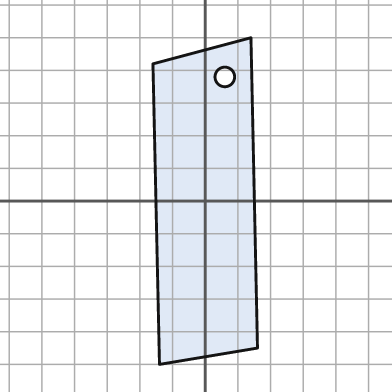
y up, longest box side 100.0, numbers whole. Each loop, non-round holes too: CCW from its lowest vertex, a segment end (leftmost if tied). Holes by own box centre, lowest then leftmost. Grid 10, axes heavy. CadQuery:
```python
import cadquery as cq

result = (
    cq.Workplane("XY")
    .moveTo(-14.0, -50.0)
    .lineTo(16.0, -45.0)
    .lineTo(14.0, 50.0)
    .lineTo(-16.0, 42.0)
    .close()
    .moveTo(6.0, 38.0)
    .circle(3.0)
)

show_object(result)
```